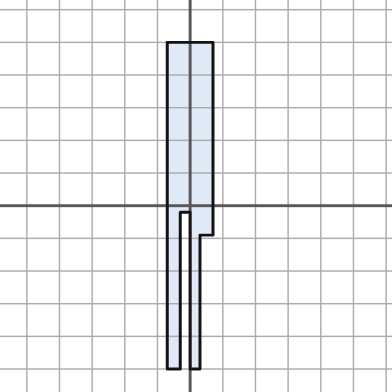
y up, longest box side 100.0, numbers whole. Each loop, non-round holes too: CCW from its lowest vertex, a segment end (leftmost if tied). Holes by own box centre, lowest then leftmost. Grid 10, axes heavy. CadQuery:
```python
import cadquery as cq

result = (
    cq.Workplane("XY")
    .moveTo(-7.0, -50.0)
    .lineTo(-3.0, -50.0)
    .lineTo(-3.0, -2.0)
    .lineTo(0.0, -2.0)
    .lineTo(0.0, -50.0)
    .lineTo(3.0, -50.0)
    .lineTo(3.0, -9.0)
    .lineTo(7.0, -9.0)
    .lineTo(7.0, 50.0)
    .lineTo(-7.0, 50.0)
    .close()
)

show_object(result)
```